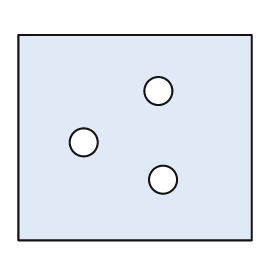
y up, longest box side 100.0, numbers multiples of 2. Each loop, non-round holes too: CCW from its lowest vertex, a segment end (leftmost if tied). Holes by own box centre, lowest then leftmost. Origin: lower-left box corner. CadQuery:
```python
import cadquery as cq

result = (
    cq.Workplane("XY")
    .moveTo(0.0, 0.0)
    .lineTo(100.0, 0.0)
    .lineTo(100.0, 88.0)
    .lineTo(0.0, 88.0)
    .close()
    .moveTo(62.0, 26.0)
    .circle(6.0)
    .moveTo(28.0, 42.0)
    .circle(6.0)
    .moveTo(60.0, 64.0)
    .circle(6.0)
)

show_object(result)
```